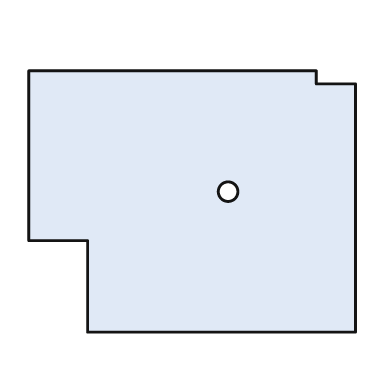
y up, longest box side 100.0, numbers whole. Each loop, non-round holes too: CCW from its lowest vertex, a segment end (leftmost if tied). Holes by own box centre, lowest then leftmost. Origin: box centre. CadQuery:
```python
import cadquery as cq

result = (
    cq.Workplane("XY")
    .moveTo(-32.0, -40.0)
    .lineTo(50.0, -40.0)
    .lineTo(50.0, 36.0)
    .lineTo(38.0, 36.0)
    .lineTo(38.0, 40.0)
    .lineTo(-50.0, 40.0)
    .lineTo(-50.0, -12.0)
    .lineTo(-32.0, -12.0)
    .close()
    .moveTo(11.0, 3.0)
    .circle(3.0)
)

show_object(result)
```